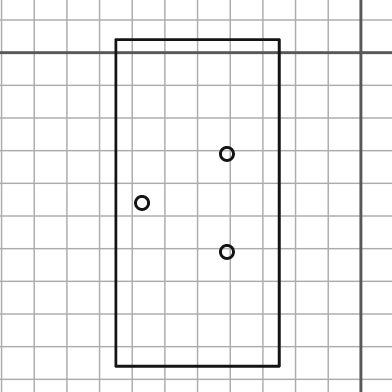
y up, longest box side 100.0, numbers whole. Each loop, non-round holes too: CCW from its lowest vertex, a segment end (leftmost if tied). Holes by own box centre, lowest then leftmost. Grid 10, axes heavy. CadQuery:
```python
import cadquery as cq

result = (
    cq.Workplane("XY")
    .moveTo(-75.0, -96.0)
    .lineTo(-25.0, -96.0)
    .lineTo(-25.0, 4.0)
    .lineTo(-75.0, 4.0)
    .close()
    .moveTo(-41.0, -61.0)
    .circle(2.0)
    .moveTo(-67.0, -46.0)
    .circle(2.0)
    .moveTo(-41.0, -31.0)
    .circle(2.0)
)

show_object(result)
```